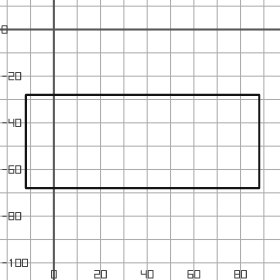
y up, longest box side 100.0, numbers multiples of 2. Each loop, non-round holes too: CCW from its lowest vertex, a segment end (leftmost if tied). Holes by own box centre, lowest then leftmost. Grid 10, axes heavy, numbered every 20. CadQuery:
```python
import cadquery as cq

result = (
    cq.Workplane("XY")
    .moveTo(-12.0, -68.0)
    .lineTo(88.0, -68.0)
    .lineTo(88.0, -28.0)
    .lineTo(-12.0, -28.0)
    .close()
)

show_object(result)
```